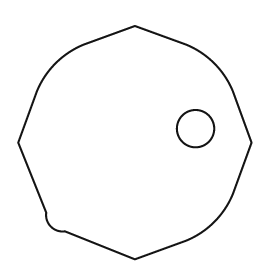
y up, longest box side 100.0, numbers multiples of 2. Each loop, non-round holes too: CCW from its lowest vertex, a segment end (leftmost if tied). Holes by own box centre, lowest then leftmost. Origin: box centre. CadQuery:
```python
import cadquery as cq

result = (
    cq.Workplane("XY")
    .moveTo(0.0, -50.0)
    .lineTo(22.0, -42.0)
    .threePointArc((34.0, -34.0), (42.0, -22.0))
    .lineTo(50.0, 0.0)
    .lineTo(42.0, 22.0)
    .threePointArc((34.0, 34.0), (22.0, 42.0))
    .lineTo(0.0, 50.0)
    .lineTo(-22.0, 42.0)
    .threePointArc((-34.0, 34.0), (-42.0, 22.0))
    .lineTo(-50.0, 0.0)
    .lineTo(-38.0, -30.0)
    .threePointArc((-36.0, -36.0), (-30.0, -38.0))
    .close()
    .moveTo(26.0, 6.0)
    .circle(8.0)
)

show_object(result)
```